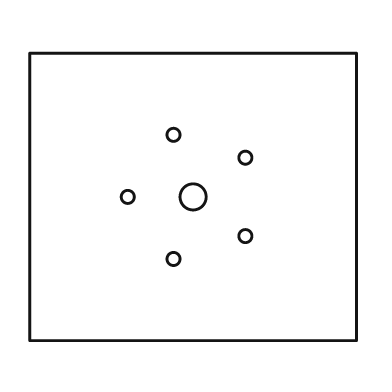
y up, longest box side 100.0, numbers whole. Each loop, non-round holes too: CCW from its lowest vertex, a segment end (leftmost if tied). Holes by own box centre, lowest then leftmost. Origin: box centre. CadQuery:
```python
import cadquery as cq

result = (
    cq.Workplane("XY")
    .moveTo(-50.0, -44.0)
    .lineTo(50.0, -44.0)
    .lineTo(50.0, 44.0)
    .lineTo(-50.0, 44.0)
    .close()
    .moveTo(-6.0, -19.0)
    .circle(2.0)
    .moveTo(16.0, -12.0)
    .circle(2.0)
    .moveTo(-20.0, 0.0)
    .circle(2.0)
    .moveTo(0.0, 0.0)
    .circle(4.0)
    .moveTo(16.0, 12.0)
    .circle(2.0)
    .moveTo(-6.0, 19.0)
    .circle(2.0)
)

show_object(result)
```